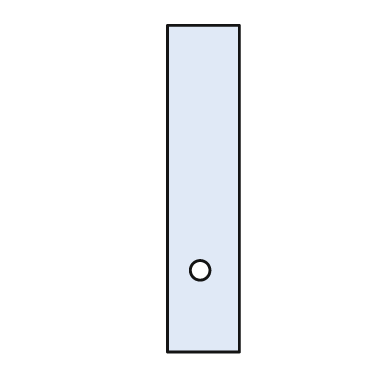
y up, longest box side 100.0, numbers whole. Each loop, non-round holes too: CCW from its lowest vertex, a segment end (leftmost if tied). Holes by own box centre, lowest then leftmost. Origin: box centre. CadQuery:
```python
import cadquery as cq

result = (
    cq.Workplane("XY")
    .moveTo(-11.0, -50.0)
    .lineTo(11.0, -50.0)
    .lineTo(11.0, 50.0)
    .lineTo(-11.0, 50.0)
    .close()
    .moveTo(-1.0, -25.0)
    .circle(3.0)
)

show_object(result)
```